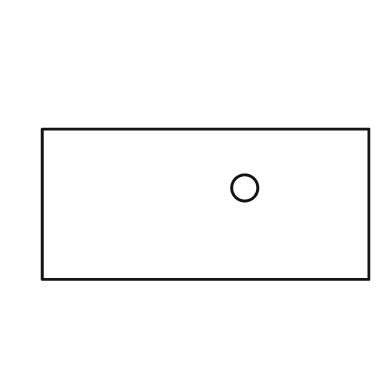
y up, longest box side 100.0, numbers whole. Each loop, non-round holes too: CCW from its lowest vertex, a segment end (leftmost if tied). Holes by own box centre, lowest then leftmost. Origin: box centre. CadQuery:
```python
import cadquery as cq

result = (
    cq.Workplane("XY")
    .moveTo(-50.0, -23.0)
    .lineTo(50.0, -23.0)
    .lineTo(50.0, 23.0)
    .lineTo(-50.0, 23.0)
    .close()
    .moveTo(12.0, 5.0)
    .circle(4.0)
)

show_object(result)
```